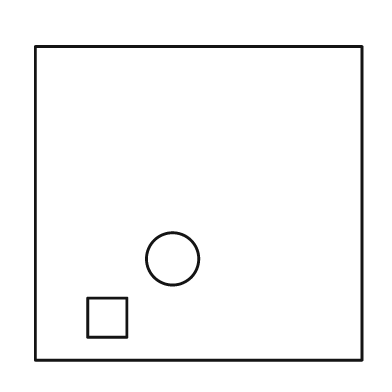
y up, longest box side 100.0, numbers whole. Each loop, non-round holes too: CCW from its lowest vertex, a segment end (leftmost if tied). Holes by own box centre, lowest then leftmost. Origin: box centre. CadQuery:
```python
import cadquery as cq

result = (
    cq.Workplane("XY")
    .moveTo(-50.0, -48.0)
    .lineTo(50.0, -48.0)
    .lineTo(50.0, 48.0)
    .lineTo(-50.0, 48.0)
    .close()
    .moveTo(-34.0, -41.0)
    .lineTo(-22.0, -41.0)
    .lineTo(-22.0, -29.0)
    .lineTo(-34.0, -29.0)
    .close()
    .moveTo(-8.0, -17.0)
    .circle(8.0)
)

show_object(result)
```